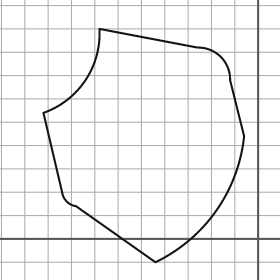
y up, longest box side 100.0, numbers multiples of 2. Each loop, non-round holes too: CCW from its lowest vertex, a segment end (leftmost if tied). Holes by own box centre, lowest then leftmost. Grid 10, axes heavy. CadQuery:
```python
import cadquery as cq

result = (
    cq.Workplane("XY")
    .moveTo(-44.0, -10.0)
    .threePointArc((-18.0, 12.0), (-6.0, 44.0))
    .lineTo(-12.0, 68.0)
    .threePointArc((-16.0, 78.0), (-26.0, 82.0))
    .lineTo(-68.0, 90.0)
    .threePointArc((-74.0, 68.0), (-92.0, 54.0))
    .lineTo(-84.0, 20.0)
    .threePointArc((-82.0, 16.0), (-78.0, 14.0))
    .close()
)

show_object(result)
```